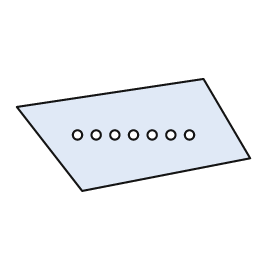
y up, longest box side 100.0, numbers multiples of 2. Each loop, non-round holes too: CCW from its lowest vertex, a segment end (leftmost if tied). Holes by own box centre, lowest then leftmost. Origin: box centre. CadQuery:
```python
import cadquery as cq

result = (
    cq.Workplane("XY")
    .moveTo(-22.0, -24.0)
    .lineTo(50.0, -10.0)
    .lineTo(30.0, 24.0)
    .lineTo(-50.0, 12.0)
    .close()
    .moveTo(-24.0, 0.0)
    .circle(2.0)
    .moveTo(-16.0, 0.0)
    .circle(2.0)
    .moveTo(-8.0, 0.0)
    .circle(2.0)
    .moveTo(0.0, 0.0)
    .circle(2.0)
    .moveTo(8.0, 0.0)
    .circle(2.0)
    .moveTo(16.0, 0.0)
    .circle(2.0)
    .moveTo(24.0, 0.0)
    .circle(2.0)
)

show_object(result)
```